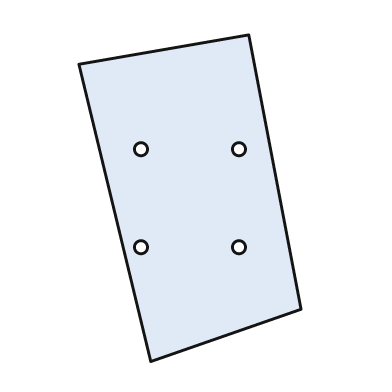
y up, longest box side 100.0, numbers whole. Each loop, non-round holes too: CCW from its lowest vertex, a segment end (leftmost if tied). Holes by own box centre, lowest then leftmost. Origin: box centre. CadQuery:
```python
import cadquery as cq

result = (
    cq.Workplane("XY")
    .moveTo(-12.0, -50.0)
    .lineTo(34.0, -34.0)
    .lineTo(18.0, 50.0)
    .lineTo(-34.0, 41.0)
    .close()
    .moveTo(-15.0, -15.0)
    .circle(2.0)
    .moveTo(15.0, -15.0)
    .circle(2.0)
    .moveTo(-15.0, 15.0)
    .circle(2.0)
    .moveTo(15.0, 15.0)
    .circle(2.0)
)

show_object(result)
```